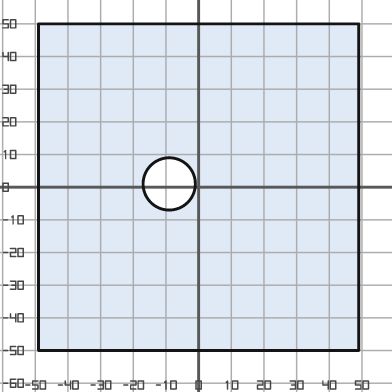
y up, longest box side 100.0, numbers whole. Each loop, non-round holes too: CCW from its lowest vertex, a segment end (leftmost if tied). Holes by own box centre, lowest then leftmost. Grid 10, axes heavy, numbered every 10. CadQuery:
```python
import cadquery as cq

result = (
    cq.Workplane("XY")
    .moveTo(-49.0, -50.0)
    .lineTo(49.0, -50.0)
    .lineTo(49.0, 50.0)
    .lineTo(-49.0, 50.0)
    .close()
    .moveTo(-9.0, 1.0)
    .circle(8.0)
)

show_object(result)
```